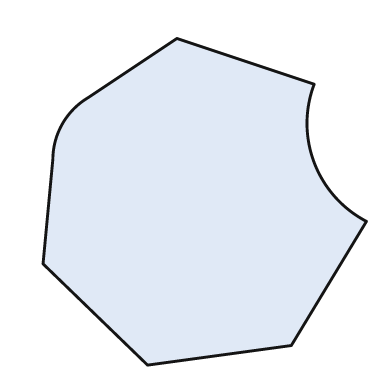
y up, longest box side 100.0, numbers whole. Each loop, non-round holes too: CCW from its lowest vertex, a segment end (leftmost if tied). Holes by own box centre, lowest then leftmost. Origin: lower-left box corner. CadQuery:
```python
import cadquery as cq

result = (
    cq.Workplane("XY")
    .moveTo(32.0, 0.0)
    .lineTo(76.0, 6.0)
    .lineTo(99.0, 44.0)
    .threePointArc((83.0, 62.0), (83.0, 86.0))
    .lineTo(41.0, 100.0)
    .lineTo(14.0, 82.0)
    .threePointArc((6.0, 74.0), (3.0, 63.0))
    .lineTo(0.0, 31.0)
    .close()
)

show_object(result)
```